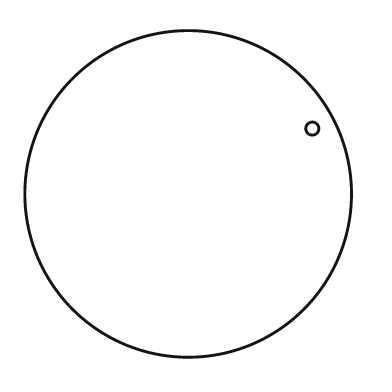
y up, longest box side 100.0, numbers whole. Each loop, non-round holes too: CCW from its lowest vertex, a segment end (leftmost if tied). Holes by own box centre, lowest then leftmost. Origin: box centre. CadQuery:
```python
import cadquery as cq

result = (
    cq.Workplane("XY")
    .moveTo(0.0, 0.0)
    .circle(50.0)
    .moveTo(38.0, 20.0)
    .circle(2.0)
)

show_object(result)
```